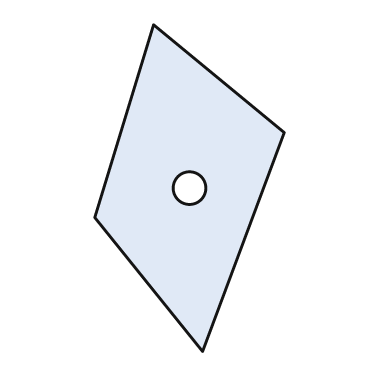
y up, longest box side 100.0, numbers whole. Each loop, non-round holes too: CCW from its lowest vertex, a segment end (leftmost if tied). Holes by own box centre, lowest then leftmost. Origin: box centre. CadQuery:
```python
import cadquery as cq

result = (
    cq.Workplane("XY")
    .moveTo(4.0, -50.0)
    .lineTo(29.0, 17.0)
    .lineTo(-11.0, 50.0)
    .lineTo(-29.0, -9.0)
    .close()
    .moveTo(0.0, 0.0)
    .circle(5.0)
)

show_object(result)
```